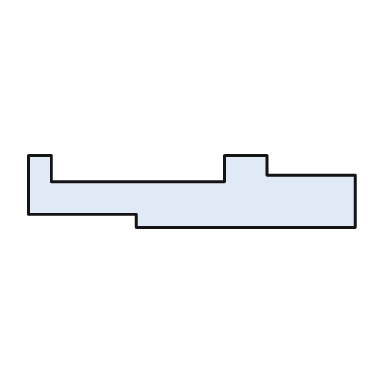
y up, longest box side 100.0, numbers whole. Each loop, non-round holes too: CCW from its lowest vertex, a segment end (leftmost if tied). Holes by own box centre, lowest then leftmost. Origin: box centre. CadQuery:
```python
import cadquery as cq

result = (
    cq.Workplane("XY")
    .moveTo(-17.0, -11.0)
    .lineTo(50.0, -11.0)
    .lineTo(50.0, 5.0)
    .lineTo(23.0, 5.0)
    .lineTo(23.0, 11.0)
    .lineTo(10.0, 11.0)
    .lineTo(10.0, 3.0)
    .lineTo(-43.0, 3.0)
    .lineTo(-43.0, 11.0)
    .lineTo(-50.0, 11.0)
    .lineTo(-50.0, -7.0)
    .lineTo(-17.0, -7.0)
    .close()
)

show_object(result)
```